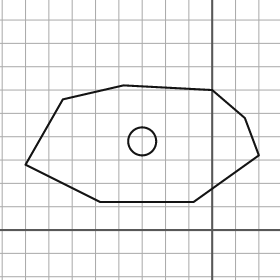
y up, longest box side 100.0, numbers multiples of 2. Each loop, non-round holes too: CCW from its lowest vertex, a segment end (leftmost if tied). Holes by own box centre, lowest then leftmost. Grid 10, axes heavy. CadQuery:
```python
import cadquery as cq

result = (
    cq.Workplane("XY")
    .moveTo(-48.0, 12.0)
    .lineTo(-8.0, 12.0)
    .lineTo(20.0, 32.0)
    .lineTo(14.0, 48.0)
    .lineTo(0.0, 60.0)
    .lineTo(-38.0, 62.0)
    .lineTo(-64.0, 56.0)
    .lineTo(-80.0, 28.0)
    .close()
    .moveTo(-30.0, 38.0)
    .circle(6.0)
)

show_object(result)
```